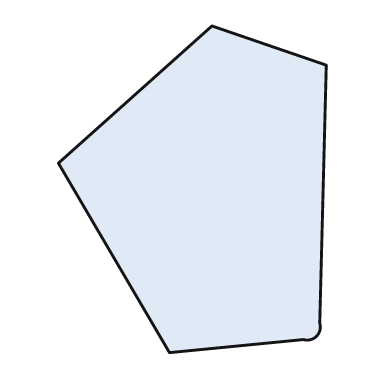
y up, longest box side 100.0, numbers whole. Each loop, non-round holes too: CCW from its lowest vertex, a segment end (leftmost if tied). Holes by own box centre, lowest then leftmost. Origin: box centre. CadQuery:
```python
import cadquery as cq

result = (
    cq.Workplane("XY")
    .moveTo(-7.0, -50.0)
    .lineTo(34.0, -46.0)
    .threePointArc((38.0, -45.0), (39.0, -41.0))
    .lineTo(41.0, 38.0)
    .lineTo(6.0, 50.0)
    .lineTo(-41.0, 8.0)
    .close()
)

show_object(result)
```